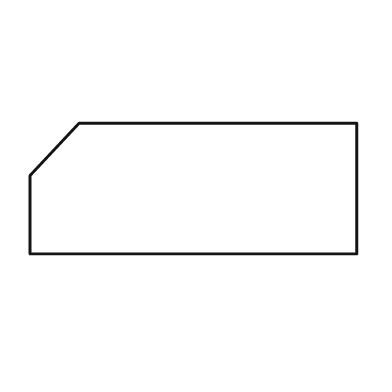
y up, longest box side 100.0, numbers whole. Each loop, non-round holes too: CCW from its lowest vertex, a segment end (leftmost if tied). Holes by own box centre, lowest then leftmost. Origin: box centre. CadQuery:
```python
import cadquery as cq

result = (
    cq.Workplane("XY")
    .moveTo(-50.0, -20.0)
    .lineTo(50.0, -20.0)
    .lineTo(50.0, 20.0)
    .lineTo(-35.0, 20.0)
    .lineTo(-50.0, 4.0)
    .close()
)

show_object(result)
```